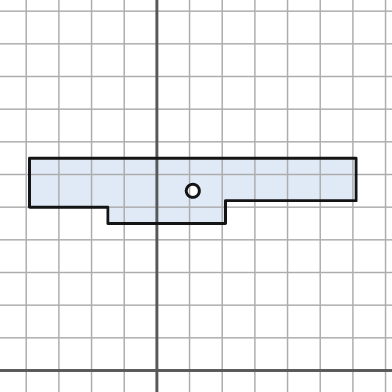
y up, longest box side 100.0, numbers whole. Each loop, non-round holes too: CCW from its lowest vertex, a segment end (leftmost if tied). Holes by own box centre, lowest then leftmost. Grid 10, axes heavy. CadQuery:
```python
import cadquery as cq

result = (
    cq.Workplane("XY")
    .moveTo(-15.0, 45.0)
    .lineTo(21.0, 45.0)
    .lineTo(21.0, 52.0)
    .lineTo(61.0, 52.0)
    .lineTo(61.0, 65.0)
    .lineTo(-39.0, 65.0)
    .lineTo(-39.0, 50.0)
    .lineTo(-15.0, 50.0)
    .close()
    .moveTo(11.0, 55.0)
    .circle(2.0)
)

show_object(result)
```